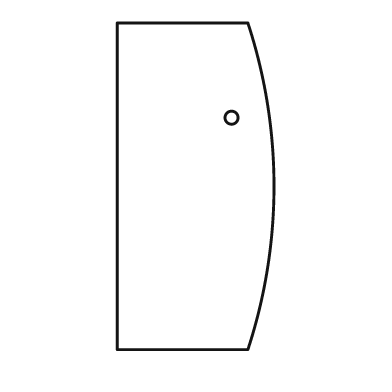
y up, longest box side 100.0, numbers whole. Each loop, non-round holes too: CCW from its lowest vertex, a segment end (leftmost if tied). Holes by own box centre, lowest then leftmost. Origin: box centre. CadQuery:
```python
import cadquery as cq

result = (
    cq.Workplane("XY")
    .moveTo(-24.0, -50.0)
    .lineTo(16.0, -50.0)
    .threePointArc((24.0, 0.0), (16.0, 50.0))
    .lineTo(-24.0, 50.0)
    .close()
    .moveTo(11.0, 21.0)
    .circle(2.0)
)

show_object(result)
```